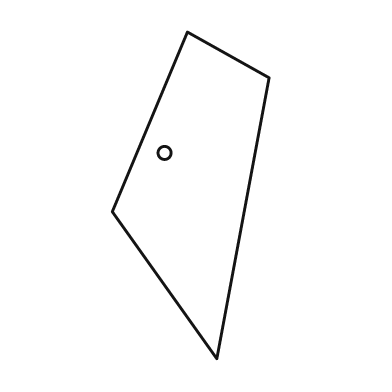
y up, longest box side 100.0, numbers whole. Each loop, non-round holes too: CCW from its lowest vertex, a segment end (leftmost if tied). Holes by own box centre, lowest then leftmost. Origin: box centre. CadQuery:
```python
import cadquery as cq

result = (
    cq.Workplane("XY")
    .moveTo(8.0, -50.0)
    .lineTo(24.0, 36.0)
    .lineTo(-1.0, 50.0)
    .lineTo(-24.0, -5.0)
    .close()
    .moveTo(-8.0, 13.0)
    .circle(2.0)
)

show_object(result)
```